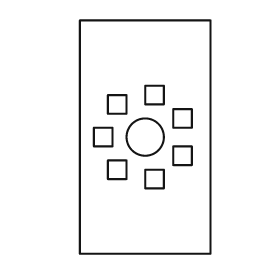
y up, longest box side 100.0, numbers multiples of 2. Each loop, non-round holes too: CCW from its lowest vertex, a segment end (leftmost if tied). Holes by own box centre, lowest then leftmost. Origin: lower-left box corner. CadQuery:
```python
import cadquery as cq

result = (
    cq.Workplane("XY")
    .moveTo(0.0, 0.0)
    .lineTo(56.0, 0.0)
    .lineTo(56.0, 100.0)
    .lineTo(0.0, 100.0)
    .close()
    .moveTo(28.0, 28.0)
    .lineTo(36.0, 28.0)
    .lineTo(36.0, 36.0)
    .lineTo(28.0, 36.0)
    .close()
    .moveTo(12.0, 32.0)
    .lineTo(20.0, 32.0)
    .lineTo(20.0, 40.0)
    .lineTo(12.0, 40.0)
    .close()
    .moveTo(40.0, 38.0)
    .lineTo(48.0, 38.0)
    .lineTo(48.0, 46.0)
    .lineTo(40.0, 46.0)
    .close()
    .moveTo(6.0, 46.0)
    .lineTo(14.0, 46.0)
    .lineTo(14.0, 54.0)
    .lineTo(6.0, 54.0)
    .close()
    .moveTo(28.0, 50.0)
    .circle(8.0)
    .moveTo(40.0, 54.0)
    .lineTo(48.0, 54.0)
    .lineTo(48.0, 62.0)
    .lineTo(40.0, 62.0)
    .close()
    .moveTo(12.0, 60.0)
    .lineTo(20.0, 60.0)
    .lineTo(20.0, 68.0)
    .lineTo(12.0, 68.0)
    .close()
    .moveTo(28.0, 64.0)
    .lineTo(36.0, 64.0)
    .lineTo(36.0, 72.0)
    .lineTo(28.0, 72.0)
    .close()
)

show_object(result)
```